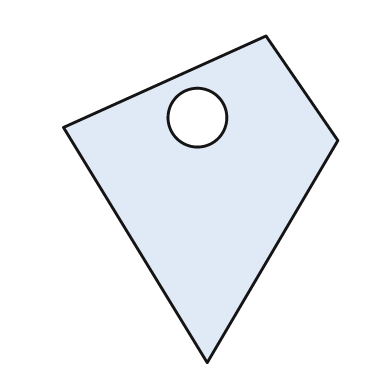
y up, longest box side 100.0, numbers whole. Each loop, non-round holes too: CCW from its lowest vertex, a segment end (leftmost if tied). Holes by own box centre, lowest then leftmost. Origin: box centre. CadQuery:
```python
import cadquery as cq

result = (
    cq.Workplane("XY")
    .moveTo(2.0, -50.0)
    .lineTo(42.0, 18.0)
    .lineTo(20.0, 50.0)
    .lineTo(-42.0, 22.0)
    .close()
    .moveTo(-1.0, 25.0)
    .circle(9.0)
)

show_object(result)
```